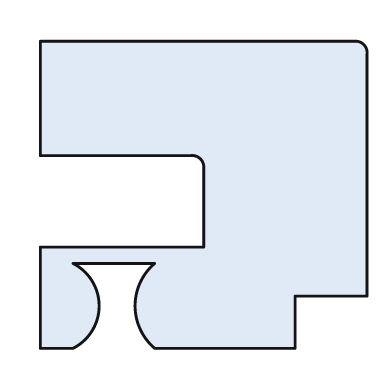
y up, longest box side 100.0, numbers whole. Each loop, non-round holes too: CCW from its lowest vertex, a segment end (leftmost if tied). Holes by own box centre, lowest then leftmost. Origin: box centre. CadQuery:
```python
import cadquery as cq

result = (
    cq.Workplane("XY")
    .moveTo(-50.0, -47.0)
    .lineTo(-40.0, -47.0)
    .threePointArc((-32.0, -34.0), (-40.0, -21.0))
    .lineTo(-15.0, -21.0)
    .threePointArc((-21.0, -34.0), (-15.0, -47.0))
    .lineTo(28.0, -47.0)
    .lineTo(28.0, -31.0)
    .lineTo(50.0, -31.0)
    .lineTo(50.0, 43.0)
    .threePointArc((49.0, 46.0), (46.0, 47.0))
    .lineTo(-50.0, 47.0)
    .lineTo(-50.0, 12.0)
    .lineTo(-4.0, 12.0)
    .threePointArc((-1.0, 11.0), (0.0, 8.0))
    .lineTo(0.0, -16.0)
    .lineTo(-50.0, -16.0)
    .close()
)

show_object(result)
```